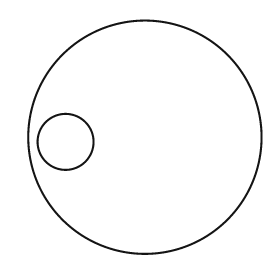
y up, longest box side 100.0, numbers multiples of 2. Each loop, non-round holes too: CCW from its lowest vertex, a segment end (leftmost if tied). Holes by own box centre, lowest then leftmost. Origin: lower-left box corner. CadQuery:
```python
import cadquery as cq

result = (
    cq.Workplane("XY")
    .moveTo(50.0, 50.0)
    .circle(50.0)
    .moveTo(16.0, 48.0)
    .circle(12.0)
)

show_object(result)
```